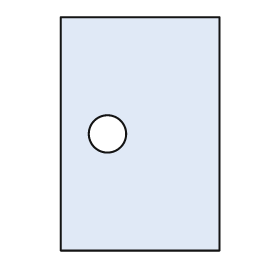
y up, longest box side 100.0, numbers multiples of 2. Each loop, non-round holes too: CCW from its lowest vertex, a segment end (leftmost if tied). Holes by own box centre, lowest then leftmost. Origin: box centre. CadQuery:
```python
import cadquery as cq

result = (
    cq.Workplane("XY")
    .moveTo(-34.0, -50.0)
    .lineTo(34.0, -50.0)
    .lineTo(34.0, 50.0)
    .lineTo(-34.0, 50.0)
    .close()
    .moveTo(-14.0, 0.0)
    .circle(8.0)
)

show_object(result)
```